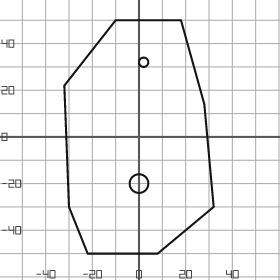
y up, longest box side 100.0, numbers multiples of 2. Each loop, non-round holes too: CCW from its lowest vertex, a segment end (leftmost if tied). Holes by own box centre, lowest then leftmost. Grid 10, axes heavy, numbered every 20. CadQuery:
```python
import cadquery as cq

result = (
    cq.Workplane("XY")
    .moveTo(-22.0, -50.0)
    .lineTo(8.0, -50.0)
    .lineTo(32.0, -30.0)
    .lineTo(28.0, 14.0)
    .lineTo(18.0, 50.0)
    .lineTo(-10.0, 50.0)
    .lineTo(-32.0, 22.0)
    .lineTo(-30.0, -30.0)
    .close()
    .moveTo(0.0, -20.0)
    .circle(4.0)
    .moveTo(2.0, 32.0)
    .circle(2.0)
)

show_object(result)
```